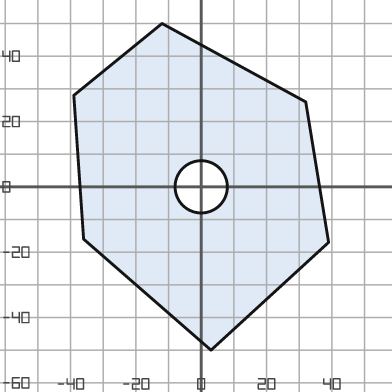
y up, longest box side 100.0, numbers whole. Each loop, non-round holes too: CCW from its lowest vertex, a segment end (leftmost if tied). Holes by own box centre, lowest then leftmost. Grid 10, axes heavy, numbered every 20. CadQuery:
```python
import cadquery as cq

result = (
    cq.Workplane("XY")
    .moveTo(3.0, -50.0)
    .lineTo(39.0, -17.0)
    .lineTo(32.0, 26.0)
    .lineTo(-12.0, 50.0)
    .lineTo(-39.0, 28.0)
    .lineTo(-36.0, -16.0)
    .close()
    .moveTo(0.0, 0.0)
    .circle(8.0)
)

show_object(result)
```